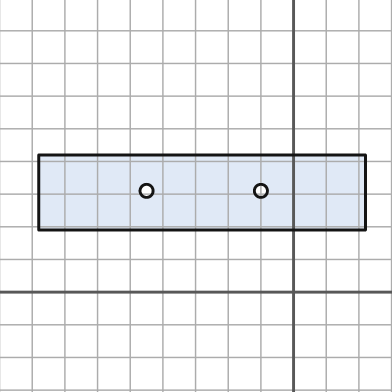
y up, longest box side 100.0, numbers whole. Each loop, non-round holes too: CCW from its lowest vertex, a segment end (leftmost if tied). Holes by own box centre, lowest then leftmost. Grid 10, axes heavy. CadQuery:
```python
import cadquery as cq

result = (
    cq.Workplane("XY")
    .moveTo(-78.0, 19.0)
    .lineTo(22.0, 19.0)
    .lineTo(22.0, 42.0)
    .lineTo(-78.0, 42.0)
    .close()
    .moveTo(-45.0, 31.0)
    .circle(2.0)
    .moveTo(-10.0, 31.0)
    .circle(2.0)
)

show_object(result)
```